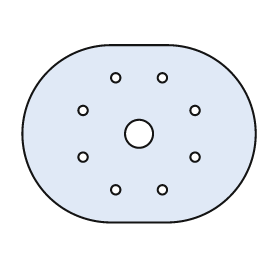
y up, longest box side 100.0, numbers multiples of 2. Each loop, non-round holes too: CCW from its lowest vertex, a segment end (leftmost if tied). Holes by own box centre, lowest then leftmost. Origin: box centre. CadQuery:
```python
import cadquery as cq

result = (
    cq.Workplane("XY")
    .moveTo(-12.0, -38.0)
    .lineTo(12.0, -38.0)
    .threePointArc((50.0, 0.0), (12.0, 38.0))
    .lineTo(-12.0, 38.0)
    .threePointArc((-50.0, 0.0), (-12.0, -38.0))
    .close()
    .moveTo(-10.0, -24.0)
    .circle(2.0)
    .moveTo(10.0, -24.0)
    .circle(2.0)
    .moveTo(-24.0, -10.0)
    .circle(2.0)
    .moveTo(24.0, -10.0)
    .circle(2.0)
    .moveTo(0.0, 0.0)
    .circle(6.0)
    .moveTo(-24.0, 10.0)
    .circle(2.0)
    .moveTo(24.0, 10.0)
    .circle(2.0)
    .moveTo(-10.0, 24.0)
    .circle(2.0)
    .moveTo(10.0, 24.0)
    .circle(2.0)
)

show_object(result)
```